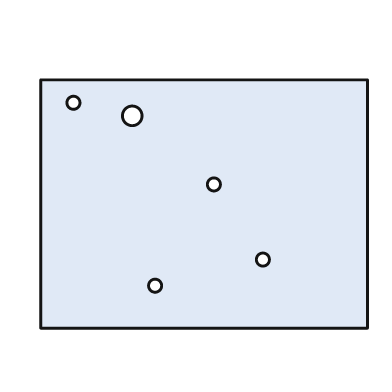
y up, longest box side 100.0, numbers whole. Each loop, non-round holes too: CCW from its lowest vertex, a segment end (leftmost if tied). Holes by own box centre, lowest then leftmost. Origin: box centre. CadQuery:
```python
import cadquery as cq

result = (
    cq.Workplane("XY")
    .moveTo(-50.0, -38.0)
    .lineTo(50.0, -38.0)
    .lineTo(50.0, 38.0)
    .lineTo(-50.0, 38.0)
    .close()
    .moveTo(-15.0, -25.0)
    .circle(2.0)
    .moveTo(18.0, -17.0)
    .circle(2.0)
    .moveTo(3.0, 6.0)
    .circle(2.0)
    .moveTo(-22.0, 27.0)
    .circle(3.0)
    .moveTo(-40.0, 31.0)
    .circle(2.0)
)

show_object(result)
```